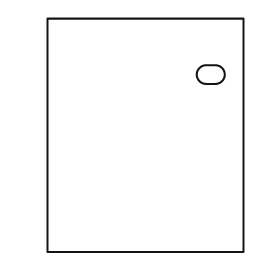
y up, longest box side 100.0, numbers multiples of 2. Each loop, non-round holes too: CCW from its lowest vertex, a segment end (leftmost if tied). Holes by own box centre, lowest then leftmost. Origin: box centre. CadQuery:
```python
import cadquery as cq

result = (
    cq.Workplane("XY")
    .moveTo(-42.0, -50.0)
    .lineTo(42.0, -50.0)
    .lineTo(42.0, 50.0)
    .lineTo(-42.0, 50.0)
    .close()
    .moveTo(26.0, 22.0)
    .lineTo(30.0, 22.0)
    .threePointArc((34.0, 26.0), (30.0, 30.0))
    .lineTo(26.0, 30.0)
    .threePointArc((22.0, 26.0), (26.0, 22.0))
    .close()
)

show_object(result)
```